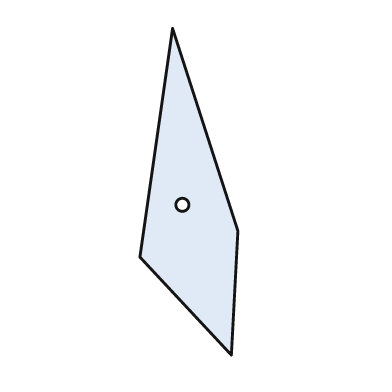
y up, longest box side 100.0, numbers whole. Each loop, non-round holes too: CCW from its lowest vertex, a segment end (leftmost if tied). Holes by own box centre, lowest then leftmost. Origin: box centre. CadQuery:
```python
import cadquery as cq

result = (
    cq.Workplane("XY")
    .moveTo(13.0, -50.0)
    .lineTo(15.0, -12.0)
    .lineTo(-5.0, 50.0)
    .lineTo(-15.0, -20.0)
    .close()
    .moveTo(-2.0, -4.0)
    .circle(2.0)
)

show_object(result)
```